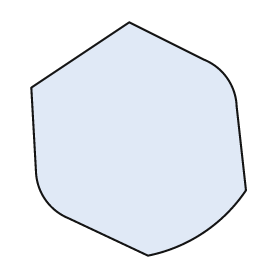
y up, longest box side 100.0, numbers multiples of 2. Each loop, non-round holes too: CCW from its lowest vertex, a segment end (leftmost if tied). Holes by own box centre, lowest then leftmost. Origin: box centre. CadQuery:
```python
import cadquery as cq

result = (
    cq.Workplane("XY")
    .moveTo(4.0, -50.0)
    .threePointArc((28.0, -40.0), (46.0, -22.0))
    .lineTo(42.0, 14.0)
    .threePointArc((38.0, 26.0), (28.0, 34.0))
    .lineTo(-4.0, 50.0)
    .lineTo(-46.0, 22.0)
    .lineTo(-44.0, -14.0)
    .threePointArc((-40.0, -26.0), (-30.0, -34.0))
    .close()
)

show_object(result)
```